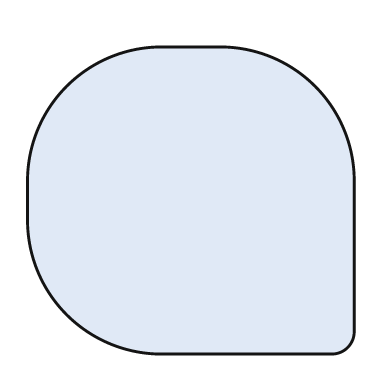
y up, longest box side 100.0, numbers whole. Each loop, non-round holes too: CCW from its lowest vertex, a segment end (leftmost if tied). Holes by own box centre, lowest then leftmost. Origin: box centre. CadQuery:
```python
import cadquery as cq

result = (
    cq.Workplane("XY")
    .moveTo(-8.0, -47.0)
    .lineTo(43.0, -47.0)
    .threePointArc((48.0, -45.0), (50.0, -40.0))
    .lineTo(50.0, 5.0)
    .threePointArc((38.0, 35.0), (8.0, 47.0))
    .lineTo(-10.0, 47.0)
    .threePointArc((-38.0, 35.0), (-50.0, 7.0))
    .lineTo(-50.0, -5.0)
    .threePointArc((-38.0, -35.0), (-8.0, -47.0))
    .close()
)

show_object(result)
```